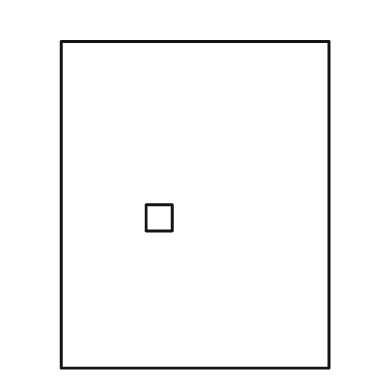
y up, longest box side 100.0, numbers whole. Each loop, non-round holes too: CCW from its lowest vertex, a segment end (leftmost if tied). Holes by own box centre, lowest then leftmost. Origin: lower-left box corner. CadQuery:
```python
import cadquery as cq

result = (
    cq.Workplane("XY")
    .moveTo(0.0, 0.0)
    .lineTo(82.0, 0.0)
    .lineTo(82.0, 100.0)
    .lineTo(0.0, 100.0)
    .close()
    .moveTo(26.0, 42.0)
    .lineTo(34.0, 42.0)
    .lineTo(34.0, 50.0)
    .lineTo(26.0, 50.0)
    .close()
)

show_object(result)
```